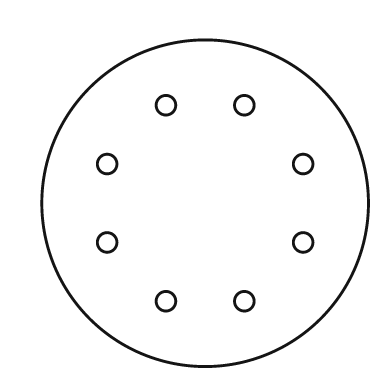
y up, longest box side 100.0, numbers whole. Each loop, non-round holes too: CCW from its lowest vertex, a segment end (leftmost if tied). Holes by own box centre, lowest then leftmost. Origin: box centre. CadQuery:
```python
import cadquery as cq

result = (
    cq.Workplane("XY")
    .moveTo(0.0, 0.0)
    .circle(50.0)
    .moveTo(-12.0, -30.0)
    .circle(3.0)
    .moveTo(12.0, -30.0)
    .circle(3.0)
    .moveTo(-30.0, -12.0)
    .circle(3.0)
    .moveTo(30.0, -12.0)
    .circle(3.0)
    .moveTo(-30.0, 12.0)
    .circle(3.0)
    .moveTo(30.0, 12.0)
    .circle(3.0)
    .moveTo(-12.0, 30.0)
    .circle(3.0)
    .moveTo(12.0, 30.0)
    .circle(3.0)
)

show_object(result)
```